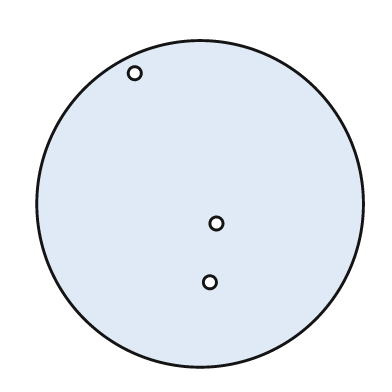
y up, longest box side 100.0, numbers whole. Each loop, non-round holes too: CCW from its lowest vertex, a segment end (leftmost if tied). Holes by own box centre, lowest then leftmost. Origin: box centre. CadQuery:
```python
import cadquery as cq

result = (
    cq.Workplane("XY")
    .moveTo(0.0, 0.0)
    .circle(50.0)
    .moveTo(3.0, -24.0)
    .circle(2.0)
    .moveTo(5.0, -6.0)
    .circle(2.0)
    .moveTo(-20.0, 40.0)
    .circle(2.0)
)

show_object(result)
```